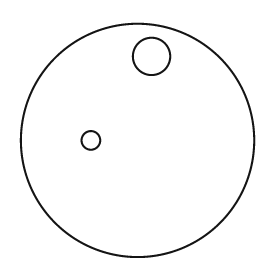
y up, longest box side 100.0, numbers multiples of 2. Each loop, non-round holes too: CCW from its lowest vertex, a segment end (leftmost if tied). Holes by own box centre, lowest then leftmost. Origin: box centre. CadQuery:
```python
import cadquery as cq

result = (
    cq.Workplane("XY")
    .moveTo(0.0, 0.0)
    .circle(50.0)
    .moveTo(-20.0, 0.0)
    .circle(4.0)
    .moveTo(6.0, 36.0)
    .circle(8.0)
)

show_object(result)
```